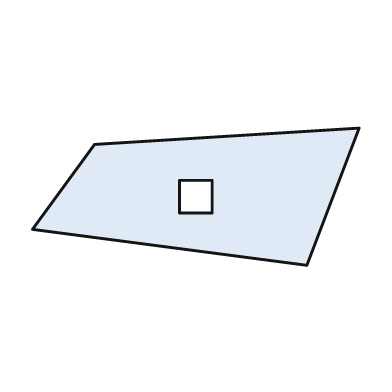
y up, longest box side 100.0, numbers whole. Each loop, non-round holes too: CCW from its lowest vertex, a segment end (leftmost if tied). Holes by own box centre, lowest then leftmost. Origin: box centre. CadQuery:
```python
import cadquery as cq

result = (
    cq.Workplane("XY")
    .moveTo(34.0, -21.0)
    .lineTo(50.0, 21.0)
    .lineTo(-31.0, 16.0)
    .lineTo(-50.0, -10.0)
    .close()
    .moveTo(-5.0, -5.0)
    .lineTo(5.0, -5.0)
    .lineTo(5.0, 5.0)
    .lineTo(-5.0, 5.0)
    .close()
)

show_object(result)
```